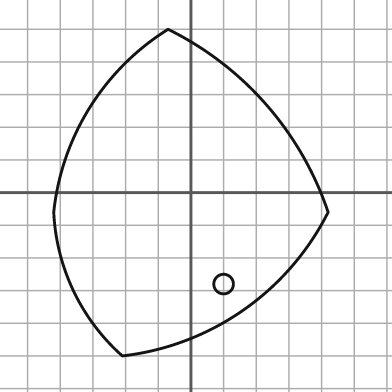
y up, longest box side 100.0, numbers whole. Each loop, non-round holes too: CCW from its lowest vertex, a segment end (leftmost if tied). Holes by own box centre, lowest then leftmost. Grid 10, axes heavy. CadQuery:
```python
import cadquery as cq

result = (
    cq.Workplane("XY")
    .moveTo(-21.0, -50.0)
    .threePointArc((16.0, -36.0), (42.0, -6.0))
    .threePointArc((23.0, 27.0), (-7.0, 50.0))
    .threePointArc((-31.0, 26.0), (-42.0, -6.0))
    .threePointArc((-36.0, -30.0), (-21.0, -50.0))
    .close()
    .moveTo(10.0, -28.0)
    .circle(3.0)
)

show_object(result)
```